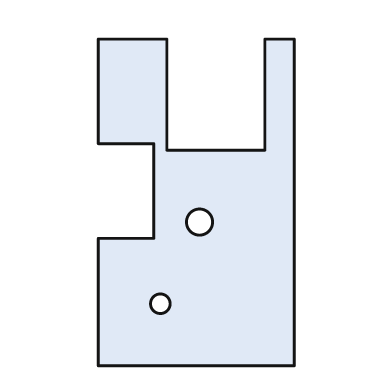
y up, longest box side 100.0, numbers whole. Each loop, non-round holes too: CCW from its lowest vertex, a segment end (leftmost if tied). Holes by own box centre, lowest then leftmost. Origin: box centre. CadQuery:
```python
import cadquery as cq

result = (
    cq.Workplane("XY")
    .moveTo(-30.0, -50.0)
    .lineTo(30.0, -50.0)
    .lineTo(30.0, 50.0)
    .lineTo(21.0, 50.0)
    .lineTo(21.0, 16.0)
    .lineTo(-9.0, 16.0)
    .lineTo(-9.0, 50.0)
    .lineTo(-30.0, 50.0)
    .lineTo(-30.0, 18.0)
    .lineTo(-13.0, 18.0)
    .lineTo(-13.0, -11.0)
    .lineTo(-30.0, -11.0)
    .close()
    .moveTo(-11.0, -31.0)
    .circle(3.0)
    .moveTo(1.0, -6.0)
    .circle(4.0)
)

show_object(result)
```